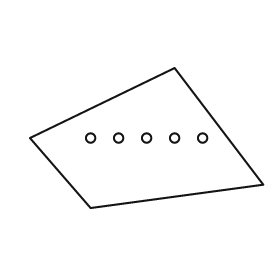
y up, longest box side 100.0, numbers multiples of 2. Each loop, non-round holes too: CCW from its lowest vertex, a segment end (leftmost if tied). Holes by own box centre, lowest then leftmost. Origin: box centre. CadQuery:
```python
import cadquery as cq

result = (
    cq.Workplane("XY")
    .moveTo(-24.0, -30.0)
    .lineTo(50.0, -20.0)
    .lineTo(12.0, 30.0)
    .lineTo(-50.0, 0.0)
    .close()
    .moveTo(-24.0, 0.0)
    .circle(2.0)
    .moveTo(-12.0, 0.0)
    .circle(2.0)
    .moveTo(0.0, 0.0)
    .circle(2.0)
    .moveTo(12.0, 0.0)
    .circle(2.0)
    .moveTo(24.0, 0.0)
    .circle(2.0)
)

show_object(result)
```